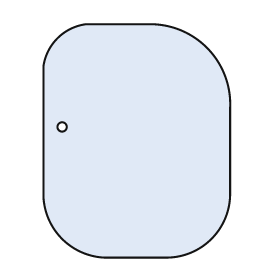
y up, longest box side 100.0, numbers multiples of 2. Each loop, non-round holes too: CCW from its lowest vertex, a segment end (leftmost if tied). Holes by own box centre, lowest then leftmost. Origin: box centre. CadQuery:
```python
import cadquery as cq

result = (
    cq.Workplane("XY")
    .moveTo(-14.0, -50.0)
    .lineTo(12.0, -50.0)
    .threePointArc((32.0, -42.0), (40.0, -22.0))
    .lineTo(40.0, 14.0)
    .threePointArc((30.0, 40.0), (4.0, 50.0))
    .lineTo(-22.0, 50.0)
    .threePointArc((-34.0, 44.0), (-40.0, 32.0))
    .lineTo(-40.0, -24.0)
    .threePointArc((-32.0, -42.0), (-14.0, -50.0))
    .close()
    .moveTo(-32.0, 6.0)
    .circle(2.0)
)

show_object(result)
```